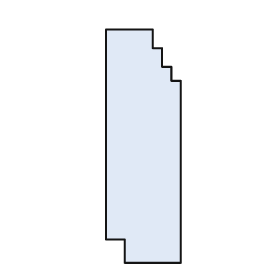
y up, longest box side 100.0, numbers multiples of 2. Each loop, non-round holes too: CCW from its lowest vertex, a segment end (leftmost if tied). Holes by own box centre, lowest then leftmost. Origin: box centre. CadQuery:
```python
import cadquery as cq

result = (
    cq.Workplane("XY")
    .moveTo(-8.0, -50.0)
    .lineTo(16.0, -50.0)
    .lineTo(16.0, 28.0)
    .lineTo(12.0, 28.0)
    .lineTo(12.0, 34.0)
    .lineTo(8.0, 34.0)
    .lineTo(8.0, 42.0)
    .lineTo(4.0, 42.0)
    .lineTo(4.0, 50.0)
    .lineTo(-16.0, 50.0)
    .lineTo(-16.0, -40.0)
    .lineTo(-8.0, -40.0)
    .close()
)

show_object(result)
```